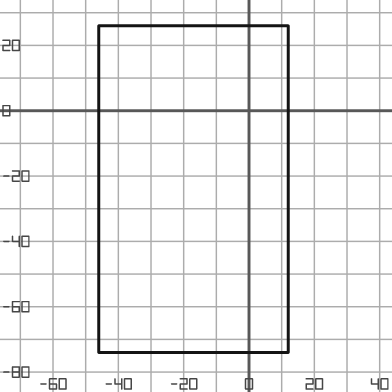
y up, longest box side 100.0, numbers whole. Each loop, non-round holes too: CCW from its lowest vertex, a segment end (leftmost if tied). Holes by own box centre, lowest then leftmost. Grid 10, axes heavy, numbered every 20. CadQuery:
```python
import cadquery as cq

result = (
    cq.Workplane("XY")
    .moveTo(-46.0, -74.0)
    .lineTo(12.0, -74.0)
    .lineTo(12.0, 26.0)
    .lineTo(-46.0, 26.0)
    .close()
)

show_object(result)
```